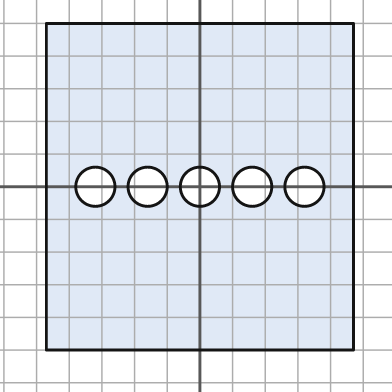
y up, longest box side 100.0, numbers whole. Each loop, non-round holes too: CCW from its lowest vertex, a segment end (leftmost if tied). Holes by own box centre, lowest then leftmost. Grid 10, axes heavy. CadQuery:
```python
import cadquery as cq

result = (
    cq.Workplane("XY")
    .moveTo(-47.0, -50.0)
    .lineTo(47.0, -50.0)
    .lineTo(47.0, 50.0)
    .lineTo(-47.0, 50.0)
    .close()
    .moveTo(-32.0, 0.0)
    .circle(6.0)
    .moveTo(-16.0, 0.0)
    .circle(6.0)
    .moveTo(0.0, 0.0)
    .circle(6.0)
    .moveTo(16.0, 0.0)
    .circle(6.0)
    .moveTo(32.0, 0.0)
    .circle(6.0)
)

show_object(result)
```